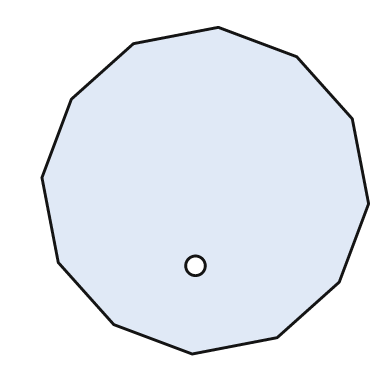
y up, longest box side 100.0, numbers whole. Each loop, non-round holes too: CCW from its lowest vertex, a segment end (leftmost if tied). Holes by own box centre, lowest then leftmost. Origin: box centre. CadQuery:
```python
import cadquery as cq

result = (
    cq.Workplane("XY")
    .moveTo(-4.0, -50.0)
    .lineTo(22.0, -45.0)
    .lineTo(41.0, -28.0)
    .lineTo(50.0, -4.0)
    .lineTo(45.0, 22.0)
    .lineTo(28.0, 41.0)
    .lineTo(4.0, 50.0)
    .lineTo(-22.0, 45.0)
    .lineTo(-41.0, 28.0)
    .lineTo(-50.0, 4.0)
    .lineTo(-45.0, -22.0)
    .lineTo(-28.0, -41.0)
    .close()
    .moveTo(-3.0, -23.0)
    .circle(3.0)
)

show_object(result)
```